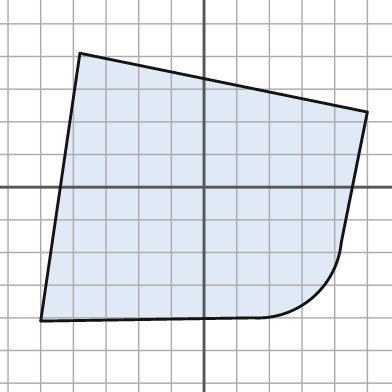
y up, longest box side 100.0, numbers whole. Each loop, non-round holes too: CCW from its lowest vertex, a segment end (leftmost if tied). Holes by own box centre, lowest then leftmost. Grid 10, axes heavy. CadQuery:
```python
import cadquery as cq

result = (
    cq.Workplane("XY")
    .moveTo(-50.0, -41.0)
    .lineTo(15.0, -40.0)
    .threePointArc((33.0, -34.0), (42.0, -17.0))
    .lineTo(50.0, 23.0)
    .lineTo(-38.0, 41.0)
    .close()
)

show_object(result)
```